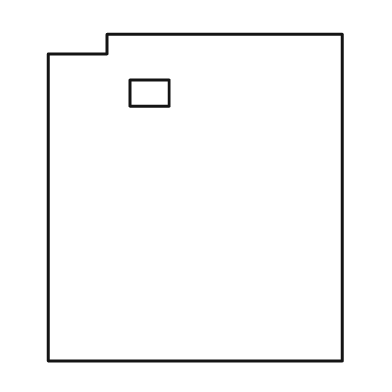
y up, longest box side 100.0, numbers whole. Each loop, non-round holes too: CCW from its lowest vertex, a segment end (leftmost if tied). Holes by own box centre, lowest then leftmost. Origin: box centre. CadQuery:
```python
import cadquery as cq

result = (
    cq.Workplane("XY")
    .moveTo(-45.0, -50.0)
    .lineTo(45.0, -50.0)
    .lineTo(45.0, 50.0)
    .lineTo(-27.0, 50.0)
    .lineTo(-27.0, 44.0)
    .lineTo(-45.0, 44.0)
    .close()
    .moveTo(-20.0, 28.0)
    .lineTo(-8.0, 28.0)
    .lineTo(-8.0, 36.0)
    .lineTo(-20.0, 36.0)
    .close()
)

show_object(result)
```